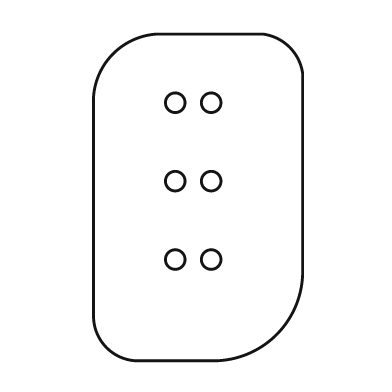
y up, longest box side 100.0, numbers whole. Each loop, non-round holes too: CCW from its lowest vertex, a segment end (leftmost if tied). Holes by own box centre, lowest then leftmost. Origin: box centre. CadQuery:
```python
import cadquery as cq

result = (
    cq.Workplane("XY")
    .moveTo(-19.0, -50.0)
    .lineTo(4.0, -50.0)
    .threePointArc((24.0, -42.0), (32.0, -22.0))
    .lineTo(32.0, 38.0)
    .threePointArc((28.0, 46.0), (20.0, 50.0))
    .lineTo(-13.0, 50.0)
    .threePointArc((-26.0, 44.0), (-32.0, 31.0))
    .lineTo(-32.0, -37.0)
    .threePointArc((-28.0, -46.0), (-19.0, -50.0))
    .close()
    .moveTo(-7.0, -19.0)
    .circle(3.0)
    .moveTo(4.0, -19.0)
    .circle(3.0)
    .moveTo(-7.0, 5.0)
    .circle(3.0)
    .moveTo(4.0, 5.0)
    .circle(3.0)
    .moveTo(-7.0, 29.0)
    .circle(3.0)
    .moveTo(4.0, 29.0)
    .circle(3.0)
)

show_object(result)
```